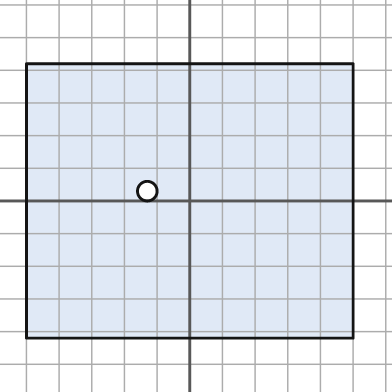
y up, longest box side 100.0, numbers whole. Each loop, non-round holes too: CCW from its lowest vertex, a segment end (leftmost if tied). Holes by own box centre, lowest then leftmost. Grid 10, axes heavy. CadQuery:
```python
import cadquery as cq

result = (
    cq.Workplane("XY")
    .moveTo(-50.0, -42.0)
    .lineTo(50.0, -42.0)
    .lineTo(50.0, 42.0)
    .lineTo(-50.0, 42.0)
    .close()
    .moveTo(-13.0, 3.0)
    .circle(3.0)
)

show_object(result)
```